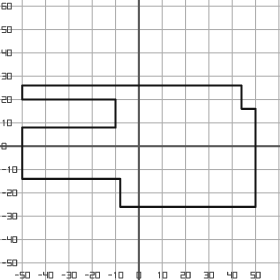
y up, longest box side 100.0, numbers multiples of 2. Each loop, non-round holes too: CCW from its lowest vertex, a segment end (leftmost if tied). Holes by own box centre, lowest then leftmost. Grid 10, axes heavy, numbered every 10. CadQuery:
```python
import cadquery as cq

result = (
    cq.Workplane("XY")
    .moveTo(-8.0, -26.0)
    .lineTo(50.0, -26.0)
    .lineTo(50.0, 16.0)
    .lineTo(44.0, 16.0)
    .lineTo(44.0, 26.0)
    .lineTo(-50.0, 26.0)
    .lineTo(-50.0, 20.0)
    .lineTo(-10.0, 20.0)
    .lineTo(-10.0, 8.0)
    .lineTo(-50.0, 8.0)
    .lineTo(-50.0, -14.0)
    .lineTo(-8.0, -14.0)
    .close()
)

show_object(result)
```